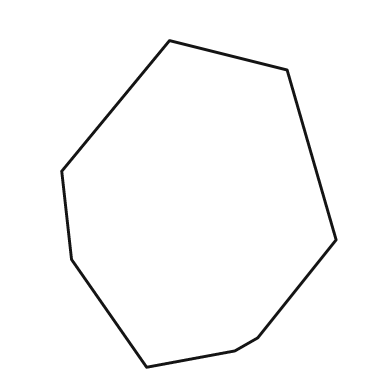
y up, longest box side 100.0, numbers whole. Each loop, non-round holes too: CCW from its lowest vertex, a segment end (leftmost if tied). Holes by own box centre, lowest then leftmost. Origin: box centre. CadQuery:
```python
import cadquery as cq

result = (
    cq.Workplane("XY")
    .moveTo(-16.0, -50.0)
    .lineTo(11.0, -45.0)
    .lineTo(18.0, -41.0)
    .lineTo(42.0, -11.0)
    .lineTo(27.0, 41.0)
    .lineTo(-9.0, 50.0)
    .lineTo(-42.0, 10.0)
    .lineTo(-39.0, -17.0)
    .close()
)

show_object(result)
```